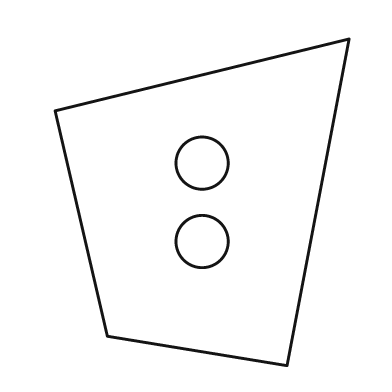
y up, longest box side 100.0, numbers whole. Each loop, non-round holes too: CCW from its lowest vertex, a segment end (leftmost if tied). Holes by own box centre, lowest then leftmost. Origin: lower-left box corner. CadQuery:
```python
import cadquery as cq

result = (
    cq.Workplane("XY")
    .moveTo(71.0, 0.0)
    .lineTo(90.0, 100.0)
    .lineTo(0.0, 78.0)
    .lineTo(16.0, 9.0)
    .close()
    .moveTo(45.0, 38.0)
    .circle(8.0)
    .moveTo(45.0, 62.0)
    .circle(8.0)
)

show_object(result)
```